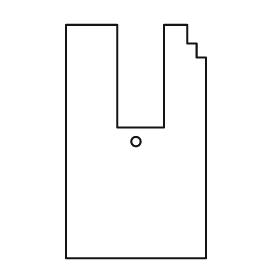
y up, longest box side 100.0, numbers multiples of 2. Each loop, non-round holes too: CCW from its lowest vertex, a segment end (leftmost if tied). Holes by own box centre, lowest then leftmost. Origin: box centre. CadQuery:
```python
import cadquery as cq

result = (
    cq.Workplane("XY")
    .moveTo(-30.0, -50.0)
    .lineTo(30.0, -50.0)
    .lineTo(30.0, 36.0)
    .lineTo(26.0, 36.0)
    .lineTo(26.0, 42.0)
    .lineTo(22.0, 42.0)
    .lineTo(22.0, 50.0)
    .lineTo(12.0, 50.0)
    .lineTo(12.0, 6.0)
    .lineTo(-8.0, 6.0)
    .lineTo(-8.0, 50.0)
    .lineTo(-30.0, 50.0)
    .close()
    .moveTo(0.0, 0.0)
    .circle(2.0)
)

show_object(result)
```